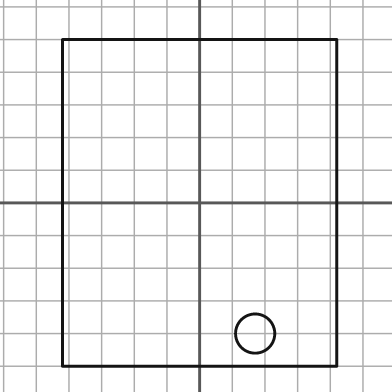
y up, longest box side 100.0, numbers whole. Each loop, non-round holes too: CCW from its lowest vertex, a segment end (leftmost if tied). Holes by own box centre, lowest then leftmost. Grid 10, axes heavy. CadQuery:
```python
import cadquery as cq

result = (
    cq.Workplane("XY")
    .moveTo(-42.0, -50.0)
    .lineTo(42.0, -50.0)
    .lineTo(42.0, 50.0)
    .lineTo(-42.0, 50.0)
    .close()
    .moveTo(17.0, -40.0)
    .circle(6.0)
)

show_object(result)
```